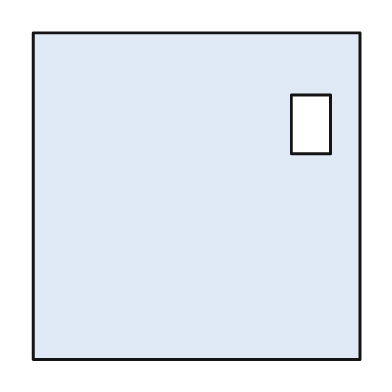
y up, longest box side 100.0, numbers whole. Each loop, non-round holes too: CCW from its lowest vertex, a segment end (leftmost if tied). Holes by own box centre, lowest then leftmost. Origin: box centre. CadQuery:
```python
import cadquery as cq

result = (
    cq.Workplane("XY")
    .moveTo(-50.0, -50.0)
    .lineTo(50.0, -50.0)
    .lineTo(50.0, 50.0)
    .lineTo(-50.0, 50.0)
    .close()
    .moveTo(29.0, 13.0)
    .lineTo(41.0, 13.0)
    .lineTo(41.0, 31.0)
    .lineTo(29.0, 31.0)
    .close()
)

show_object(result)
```